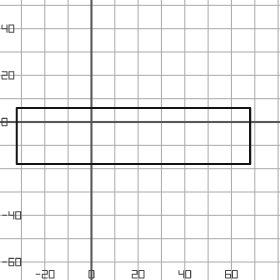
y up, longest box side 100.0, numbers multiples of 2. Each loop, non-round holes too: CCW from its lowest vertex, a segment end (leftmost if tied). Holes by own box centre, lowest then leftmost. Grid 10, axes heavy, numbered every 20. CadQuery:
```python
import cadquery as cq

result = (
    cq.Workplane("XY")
    .moveTo(-32.0, -18.0)
    .lineTo(68.0, -18.0)
    .lineTo(68.0, 6.0)
    .lineTo(-32.0, 6.0)
    .close()
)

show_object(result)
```